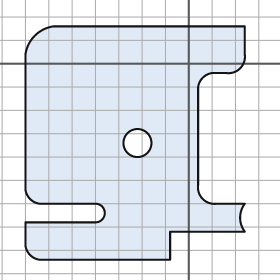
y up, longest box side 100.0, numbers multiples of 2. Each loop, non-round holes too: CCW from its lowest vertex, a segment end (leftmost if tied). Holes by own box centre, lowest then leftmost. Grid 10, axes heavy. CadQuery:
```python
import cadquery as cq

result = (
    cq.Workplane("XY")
    .moveTo(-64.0, -84.0)
    .lineTo(-8.0, -84.0)
    .lineTo(-8.0, -72.0)
    .lineTo(24.0, -72.0)
    .threePointArc((22.0, -66.0), (24.0, -60.0))
    .lineTo(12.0, -60.0)
    .threePointArc((6.0, -58.0), (4.0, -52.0))
    .lineTo(4.0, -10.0)
    .threePointArc((6.0, -6.0), (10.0, -4.0))
    .lineTo(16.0, -4.0)
    .threePointArc((22.0, -2.0), (24.0, 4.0))
    .lineTo(24.0, 16.0)
    .lineTo(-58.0, 16.0)
    .threePointArc((-66.0, 12.0), (-70.0, 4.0))
    .lineTo(-70.0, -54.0)
    .threePointArc((-68.0, -58.0), (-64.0, -60.0))
    .lineTo(-40.0, -60.0)
    .threePointArc((-36.0, -64.0), (-40.0, -68.0))
    .lineTo(-70.0, -68.0)
    .lineTo(-70.0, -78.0)
    .threePointArc((-68.0, -82.0), (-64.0, -84.0))
    .close()
    .moveTo(-22.0, -34.0)
    .circle(6.0)
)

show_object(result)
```